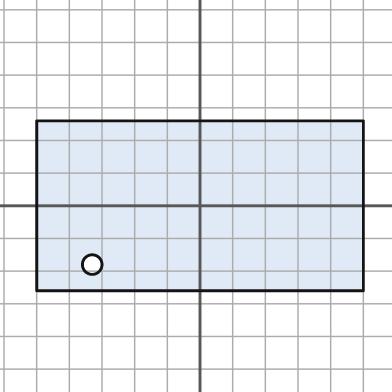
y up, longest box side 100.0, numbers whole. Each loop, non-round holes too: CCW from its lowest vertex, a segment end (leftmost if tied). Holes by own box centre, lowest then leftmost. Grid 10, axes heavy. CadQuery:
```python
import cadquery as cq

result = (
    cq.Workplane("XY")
    .moveTo(-50.0, -26.0)
    .lineTo(50.0, -26.0)
    .lineTo(50.0, 26.0)
    .lineTo(-50.0, 26.0)
    .close()
    .moveTo(-33.0, -18.0)
    .circle(3.0)
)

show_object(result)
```